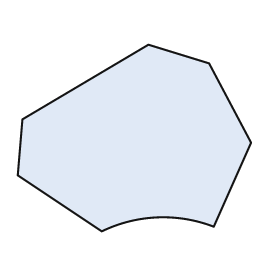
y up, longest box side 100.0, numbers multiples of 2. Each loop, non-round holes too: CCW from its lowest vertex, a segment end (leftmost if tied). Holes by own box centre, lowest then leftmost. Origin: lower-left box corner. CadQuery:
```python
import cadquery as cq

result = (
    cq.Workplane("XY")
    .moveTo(36.0, 0.0)
    .threePointArc((60.0, 6.0), (84.0, 2.0))
    .lineTo(100.0, 38.0)
    .lineTo(82.0, 72.0)
    .lineTo(56.0, 80.0)
    .lineTo(2.0, 48.0)
    .lineTo(0.0, 24.0)
    .close()
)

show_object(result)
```